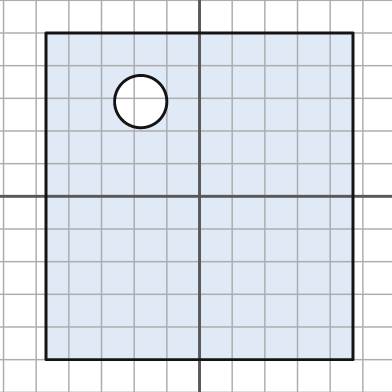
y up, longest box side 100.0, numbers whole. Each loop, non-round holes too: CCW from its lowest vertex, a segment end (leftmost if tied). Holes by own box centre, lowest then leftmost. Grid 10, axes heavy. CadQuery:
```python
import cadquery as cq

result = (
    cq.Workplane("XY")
    .moveTo(-47.0, -50.0)
    .lineTo(47.0, -50.0)
    .lineTo(47.0, 50.0)
    .lineTo(-47.0, 50.0)
    .close()
    .moveTo(-18.0, 29.0)
    .circle(8.0)
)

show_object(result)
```